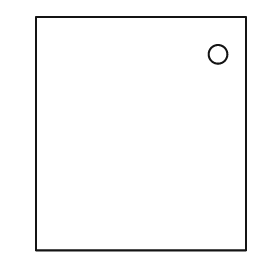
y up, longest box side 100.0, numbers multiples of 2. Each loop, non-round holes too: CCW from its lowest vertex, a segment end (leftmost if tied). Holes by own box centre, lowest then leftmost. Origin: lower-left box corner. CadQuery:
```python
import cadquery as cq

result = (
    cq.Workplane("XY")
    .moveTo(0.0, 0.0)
    .lineTo(90.0, 0.0)
    .lineTo(90.0, 100.0)
    .lineTo(0.0, 100.0)
    .close()
    .moveTo(78.0, 84.0)
    .circle(4.0)
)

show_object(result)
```